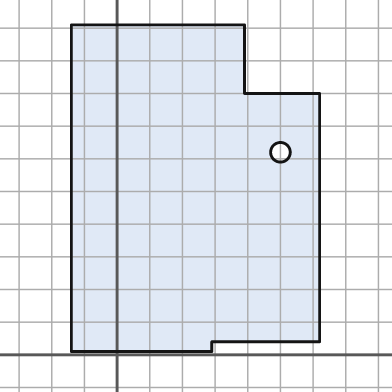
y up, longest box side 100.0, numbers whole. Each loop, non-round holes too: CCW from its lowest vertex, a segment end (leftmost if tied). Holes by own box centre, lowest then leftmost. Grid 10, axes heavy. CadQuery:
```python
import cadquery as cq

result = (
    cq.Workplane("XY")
    .moveTo(-14.0, 1.0)
    .lineTo(29.0, 1.0)
    .lineTo(29.0, 4.0)
    .lineTo(62.0, 4.0)
    .lineTo(62.0, 80.0)
    .lineTo(39.0, 80.0)
    .lineTo(39.0, 101.0)
    .lineTo(-14.0, 101.0)
    .close()
    .moveTo(50.0, 62.0)
    .circle(3.0)
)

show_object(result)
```